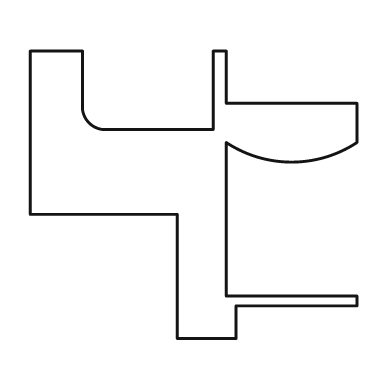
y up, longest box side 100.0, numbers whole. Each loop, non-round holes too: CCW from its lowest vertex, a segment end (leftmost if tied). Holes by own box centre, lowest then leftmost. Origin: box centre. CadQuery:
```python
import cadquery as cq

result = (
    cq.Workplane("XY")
    .moveTo(-5.0, -44.0)
    .lineTo(13.0, -44.0)
    .lineTo(13.0, -34.0)
    .lineTo(50.0, -34.0)
    .lineTo(50.0, -31.0)
    .lineTo(10.0, -31.0)
    .lineTo(10.0, 16.0)
    .threePointArc((30.0, 10.0), (50.0, 16.0))
    .lineTo(50.0, 28.0)
    .lineTo(10.0, 28.0)
    .lineTo(10.0, 44.0)
    .lineTo(6.0, 44.0)
    .lineTo(6.0, 20.0)
    .lineTo(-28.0, 20.0)
    .threePointArc((-32.0, 22.0), (-34.0, 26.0))
    .lineTo(-34.0, 44.0)
    .lineTo(-50.0, 44.0)
    .lineTo(-50.0, -6.0)
    .lineTo(-5.0, -6.0)
    .close()
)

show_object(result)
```